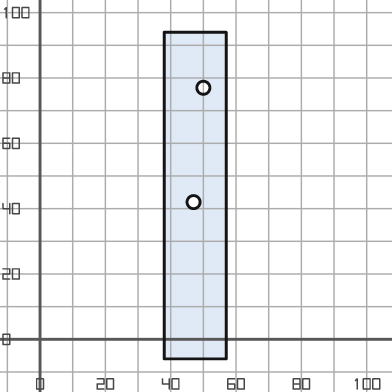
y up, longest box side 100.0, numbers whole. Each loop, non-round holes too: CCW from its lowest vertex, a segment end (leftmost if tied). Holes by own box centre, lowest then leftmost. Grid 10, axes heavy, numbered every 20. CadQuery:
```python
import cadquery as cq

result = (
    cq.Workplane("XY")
    .moveTo(38.0, -6.0)
    .lineTo(57.0, -6.0)
    .lineTo(57.0, 94.0)
    .lineTo(38.0, 94.0)
    .close()
    .moveTo(47.0, 42.0)
    .circle(2.0)
    .moveTo(50.0, 77.0)
    .circle(2.0)
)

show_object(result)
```